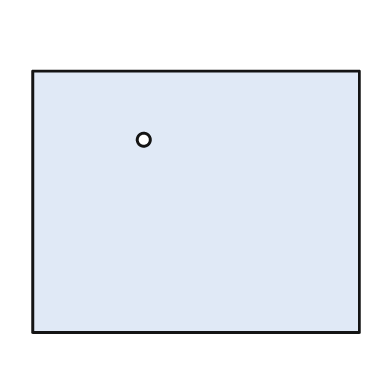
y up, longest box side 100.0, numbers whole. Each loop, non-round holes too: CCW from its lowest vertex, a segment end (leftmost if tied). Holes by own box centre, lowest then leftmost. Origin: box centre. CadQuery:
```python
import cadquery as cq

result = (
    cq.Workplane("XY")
    .moveTo(-50.0, -40.0)
    .lineTo(50.0, -40.0)
    .lineTo(50.0, 40.0)
    .lineTo(-50.0, 40.0)
    .close()
    .moveTo(-16.0, 19.0)
    .circle(2.0)
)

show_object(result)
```